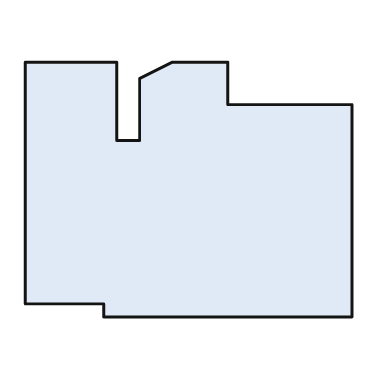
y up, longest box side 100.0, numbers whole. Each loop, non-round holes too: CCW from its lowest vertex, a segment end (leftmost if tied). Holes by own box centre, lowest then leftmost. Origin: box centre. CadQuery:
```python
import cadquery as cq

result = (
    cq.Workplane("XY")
    .moveTo(-26.0, -39.0)
    .lineTo(50.0, -39.0)
    .lineTo(50.0, 26.0)
    .lineTo(12.0, 26.0)
    .lineTo(12.0, 39.0)
    .lineTo(-5.0, 39.0)
    .lineTo(-15.0, 34.0)
    .lineTo(-15.0, 15.0)
    .lineTo(-22.0, 15.0)
    .lineTo(-22.0, 39.0)
    .lineTo(-50.0, 39.0)
    .lineTo(-50.0, -35.0)
    .lineTo(-26.0, -35.0)
    .close()
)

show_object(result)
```